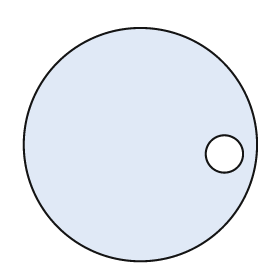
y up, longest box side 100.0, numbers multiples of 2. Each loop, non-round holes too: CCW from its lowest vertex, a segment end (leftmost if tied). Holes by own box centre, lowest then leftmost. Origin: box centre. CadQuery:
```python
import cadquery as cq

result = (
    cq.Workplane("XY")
    .moveTo(0.0, 0.0)
    .circle(50.0)
    .moveTo(36.0, -4.0)
    .circle(8.0)
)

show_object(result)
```